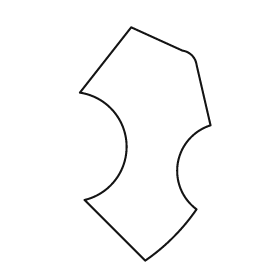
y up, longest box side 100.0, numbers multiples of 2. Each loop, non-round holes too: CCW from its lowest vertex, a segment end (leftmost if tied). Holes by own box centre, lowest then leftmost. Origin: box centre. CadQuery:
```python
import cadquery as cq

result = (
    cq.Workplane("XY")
    .moveTo(0.0, -50.0)
    .threePointArc((12.0, -40.0), (22.0, -28.0))
    .threePointArc((14.0, -8.0), (28.0, 8.0))
    .lineTo(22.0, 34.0)
    .threePointArc((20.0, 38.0), (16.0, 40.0))
    .lineTo(-6.0, 50.0)
    .lineTo(-28.0, 22.0)
    .threePointArc((-8.0, 0.0), (-26.0, -24.0))
    .close()
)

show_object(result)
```